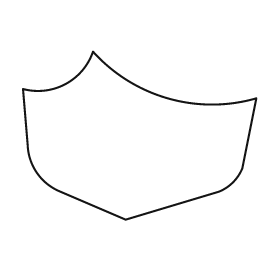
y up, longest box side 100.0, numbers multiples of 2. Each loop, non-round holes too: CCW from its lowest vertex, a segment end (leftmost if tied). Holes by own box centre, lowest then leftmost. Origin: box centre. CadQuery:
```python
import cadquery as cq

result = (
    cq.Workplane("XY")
    .moveTo(-6.0, -36.0)
    .lineTo(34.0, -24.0)
    .threePointArc((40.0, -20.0), (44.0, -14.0))
    .lineTo(50.0, 16.0)
    .threePointArc((12.0, 16.0), (-20.0, 36.0))
    .threePointArc((-32.0, 22.0), (-50.0, 20.0))
    .lineTo(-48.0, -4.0)
    .threePointArc((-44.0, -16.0), (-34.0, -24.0))
    .close()
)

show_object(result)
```